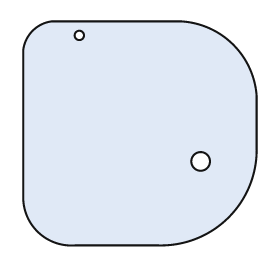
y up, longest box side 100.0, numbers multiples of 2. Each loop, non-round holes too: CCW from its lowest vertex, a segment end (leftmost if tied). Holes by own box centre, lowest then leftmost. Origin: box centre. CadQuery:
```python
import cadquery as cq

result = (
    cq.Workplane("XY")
    .moveTo(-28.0, -48.0)
    .lineTo(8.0, -48.0)
    .threePointArc((38.0, -36.0), (50.0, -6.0))
    .lineTo(50.0, 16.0)
    .threePointArc((40.0, 38.0), (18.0, 48.0))
    .lineTo(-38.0, 48.0)
    .threePointArc((-46.0, 44.0), (-50.0, 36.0))
    .lineTo(-50.0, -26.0)
    .threePointArc((-44.0, -42.0), (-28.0, -48.0))
    .close()
    .moveTo(26.0, -12.0)
    .circle(4.0)
    .moveTo(-26.0, 42.0)
    .circle(2.0)
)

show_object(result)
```